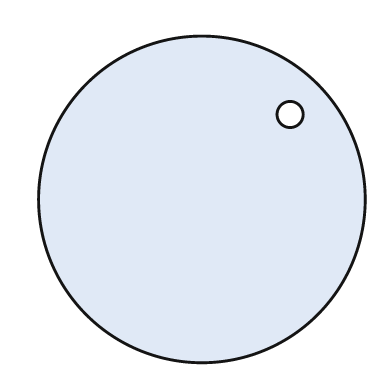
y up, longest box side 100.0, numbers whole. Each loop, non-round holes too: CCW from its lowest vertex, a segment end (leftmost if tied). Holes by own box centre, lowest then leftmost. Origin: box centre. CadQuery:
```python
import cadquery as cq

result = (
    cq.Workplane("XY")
    .moveTo(0.0, 0.0)
    .circle(50.0)
    .moveTo(27.0, 26.0)
    .circle(4.0)
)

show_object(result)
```